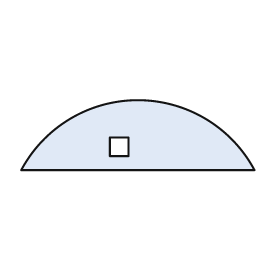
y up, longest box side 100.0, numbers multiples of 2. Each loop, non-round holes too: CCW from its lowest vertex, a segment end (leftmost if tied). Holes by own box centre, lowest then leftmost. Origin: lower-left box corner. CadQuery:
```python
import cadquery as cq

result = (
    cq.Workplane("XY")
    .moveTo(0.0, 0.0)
    .lineTo(100.0, 0.0)
    .threePointArc((50.0, 30.0), (0.0, 0.0))
    .close()
    .moveTo(38.0, 6.0)
    .lineTo(46.0, 6.0)
    .lineTo(46.0, 14.0)
    .lineTo(38.0, 14.0)
    .close()
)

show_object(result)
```